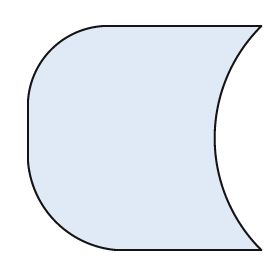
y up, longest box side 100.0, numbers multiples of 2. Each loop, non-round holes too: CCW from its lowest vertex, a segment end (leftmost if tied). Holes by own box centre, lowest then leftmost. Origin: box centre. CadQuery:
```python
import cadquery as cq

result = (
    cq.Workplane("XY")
    .moveTo(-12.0, -48.0)
    .lineTo(50.0, -48.0)
    .threePointArc((30.0, 0.0), (50.0, 48.0))
    .lineTo(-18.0, 48.0)
    .threePointArc((-40.0, 38.0), (-50.0, 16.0))
    .lineTo(-50.0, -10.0)
    .threePointArc((-38.0, -36.0), (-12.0, -48.0))
    .close()
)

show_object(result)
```